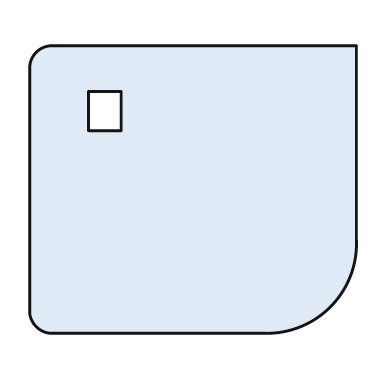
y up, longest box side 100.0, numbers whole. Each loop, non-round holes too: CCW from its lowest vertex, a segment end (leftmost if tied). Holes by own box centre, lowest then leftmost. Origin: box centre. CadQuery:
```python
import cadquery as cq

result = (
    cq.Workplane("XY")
    .moveTo(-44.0, -44.0)
    .lineTo(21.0, -44.0)
    .threePointArc((42.0, -36.0), (50.0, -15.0))
    .lineTo(50.0, 44.0)
    .lineTo(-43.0, 44.0)
    .threePointArc((-48.0, 42.0), (-50.0, 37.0))
    .lineTo(-50.0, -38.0)
    .threePointArc((-48.0, -42.0), (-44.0, -44.0))
    .close()
    .moveTo(-32.0, 18.0)
    .lineTo(-22.0, 18.0)
    .lineTo(-22.0, 30.0)
    .lineTo(-32.0, 30.0)
    .close()
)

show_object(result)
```